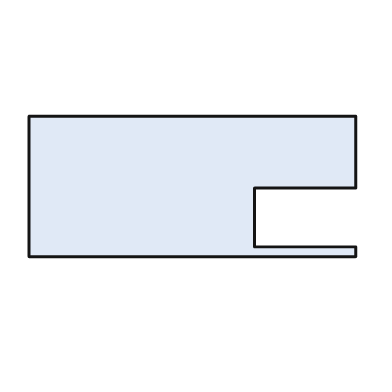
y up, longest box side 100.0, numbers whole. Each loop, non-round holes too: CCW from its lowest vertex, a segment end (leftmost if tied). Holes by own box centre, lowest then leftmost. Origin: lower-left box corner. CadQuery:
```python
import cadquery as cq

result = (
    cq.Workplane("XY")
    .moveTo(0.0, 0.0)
    .lineTo(100.0, 0.0)
    .lineTo(100.0, 3.0)
    .lineTo(69.0, 3.0)
    .lineTo(69.0, 21.0)
    .lineTo(100.0, 21.0)
    .lineTo(100.0, 43.0)
    .lineTo(0.0, 43.0)
    .close()
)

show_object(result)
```